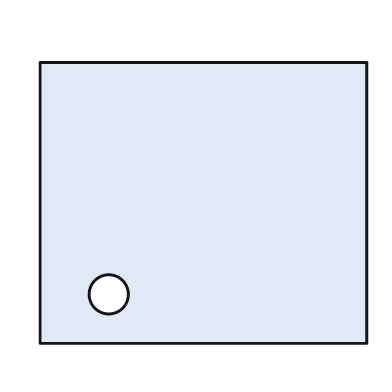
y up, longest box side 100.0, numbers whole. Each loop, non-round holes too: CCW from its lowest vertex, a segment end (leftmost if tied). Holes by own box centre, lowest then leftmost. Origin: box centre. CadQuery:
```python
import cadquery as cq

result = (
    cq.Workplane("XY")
    .moveTo(-50.0, -43.0)
    .lineTo(50.0, -43.0)
    .lineTo(50.0, 43.0)
    .lineTo(-50.0, 43.0)
    .close()
    .moveTo(-29.0, -28.0)
    .circle(6.0)
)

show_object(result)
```